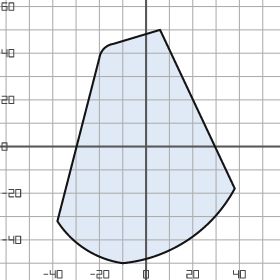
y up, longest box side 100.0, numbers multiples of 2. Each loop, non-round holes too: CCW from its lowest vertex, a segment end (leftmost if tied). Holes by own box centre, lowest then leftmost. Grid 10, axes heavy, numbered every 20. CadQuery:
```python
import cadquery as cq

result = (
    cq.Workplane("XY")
    .moveTo(-10.0, -50.0)
    .threePointArc((18.0, -40.0), (38.0, -18.0))
    .lineTo(6.0, 50.0)
    .lineTo(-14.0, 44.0)
    .threePointArc((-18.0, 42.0), (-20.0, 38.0))
    .lineTo(-38.0, -32.0)
    .threePointArc((-26.0, -44.0), (-10.0, -50.0))
    .close()
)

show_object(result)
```